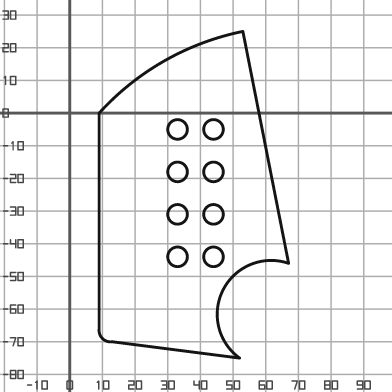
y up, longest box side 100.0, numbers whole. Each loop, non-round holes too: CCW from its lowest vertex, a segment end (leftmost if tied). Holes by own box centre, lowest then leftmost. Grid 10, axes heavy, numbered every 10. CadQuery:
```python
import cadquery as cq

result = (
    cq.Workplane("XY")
    .moveTo(52.0, -75.0)
    .threePointArc((47.0, -54.0), (67.0, -46.0))
    .lineTo(53.0, 25.0)
    .threePointArc((29.0, 16.0), (9.0, 0.0))
    .lineTo(9.0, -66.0)
    .threePointArc((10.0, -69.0), (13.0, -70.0))
    .close()
    .moveTo(33.0, -44.0)
    .circle(3.0)
    .moveTo(44.0, -44.0)
    .circle(3.0)
    .moveTo(33.0, -31.0)
    .circle(3.0)
    .moveTo(44.0, -31.0)
    .circle(3.0)
    .moveTo(33.0, -18.0)
    .circle(3.0)
    .moveTo(44.0, -18.0)
    .circle(3.0)
    .moveTo(33.0, -5.0)
    .circle(3.0)
    .moveTo(44.0, -5.0)
    .circle(3.0)
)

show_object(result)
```